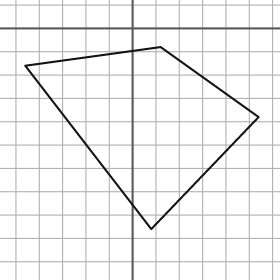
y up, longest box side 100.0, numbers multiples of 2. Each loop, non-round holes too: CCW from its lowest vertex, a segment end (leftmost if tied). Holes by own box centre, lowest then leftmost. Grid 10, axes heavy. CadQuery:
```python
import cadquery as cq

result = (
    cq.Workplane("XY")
    .moveTo(8.0, -86.0)
    .lineTo(54.0, -38.0)
    .lineTo(12.0, -8.0)
    .lineTo(-46.0, -16.0)
    .close()
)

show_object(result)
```